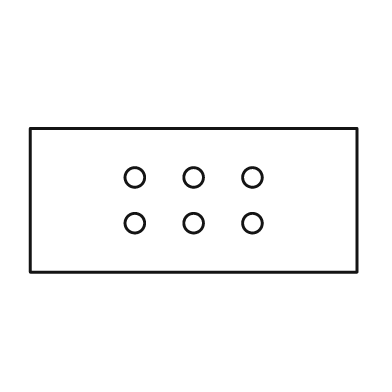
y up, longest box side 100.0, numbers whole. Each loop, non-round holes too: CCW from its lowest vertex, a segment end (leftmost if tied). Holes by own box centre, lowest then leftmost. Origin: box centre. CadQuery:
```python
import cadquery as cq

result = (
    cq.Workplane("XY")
    .moveTo(-50.0, -22.0)
    .lineTo(50.0, -22.0)
    .lineTo(50.0, 22.0)
    .lineTo(-50.0, 22.0)
    .close()
    .moveTo(-18.0, -7.0)
    .circle(3.0)
    .moveTo(0.0, -7.0)
    .circle(3.0)
    .moveTo(18.0, -7.0)
    .circle(3.0)
    .moveTo(-18.0, 7.0)
    .circle(3.0)
    .moveTo(0.0, 7.0)
    .circle(3.0)
    .moveTo(18.0, 7.0)
    .circle(3.0)
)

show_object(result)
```